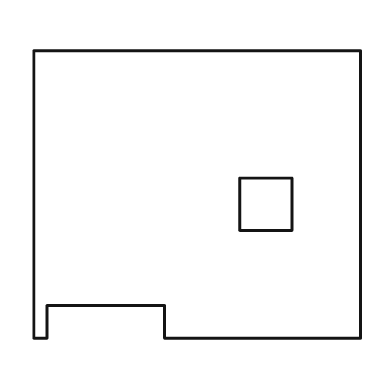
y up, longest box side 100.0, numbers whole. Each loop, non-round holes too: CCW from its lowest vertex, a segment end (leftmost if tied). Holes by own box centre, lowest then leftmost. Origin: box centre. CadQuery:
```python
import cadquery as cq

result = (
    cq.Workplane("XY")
    .moveTo(-50.0, -44.0)
    .lineTo(-46.0, -44.0)
    .lineTo(-46.0, -34.0)
    .lineTo(-10.0, -34.0)
    .lineTo(-10.0, -44.0)
    .lineTo(50.0, -44.0)
    .lineTo(50.0, 44.0)
    .lineTo(-50.0, 44.0)
    .close()
    .moveTo(13.0, -11.0)
    .lineTo(29.0, -11.0)
    .lineTo(29.0, 5.0)
    .lineTo(13.0, 5.0)
    .close()
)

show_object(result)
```